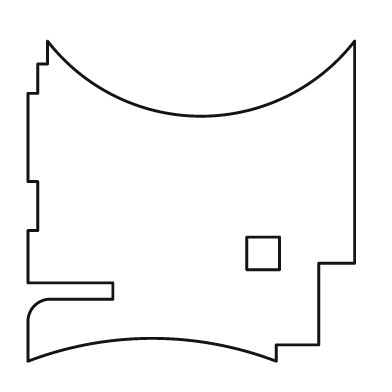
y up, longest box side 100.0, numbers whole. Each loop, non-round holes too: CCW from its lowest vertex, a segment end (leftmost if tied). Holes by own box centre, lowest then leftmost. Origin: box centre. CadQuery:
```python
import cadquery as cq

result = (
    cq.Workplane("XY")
    .moveTo(-50.0, -49.0)
    .threePointArc((-12.0, -42.0), (26.0, -49.0))
    .lineTo(26.0, -44.0)
    .lineTo(39.0, -44.0)
    .lineTo(39.0, -19.0)
    .lineTo(50.0, -19.0)
    .lineTo(50.0, 49.0)
    .threePointArc((3.0, 26.0), (-44.0, 49.0))
    .lineTo(-44.0, 42.0)
    .lineTo(-47.0, 42.0)
    .lineTo(-47.0, 33.0)
    .lineTo(-50.0, 33.0)
    .lineTo(-50.0, 6.0)
    .lineTo(-47.0, 6.0)
    .lineTo(-47.0, -9.0)
    .lineTo(-50.0, -9.0)
    .lineTo(-50.0, -25.0)
    .lineTo(-24.0, -25.0)
    .lineTo(-24.0, -30.0)
    .lineTo(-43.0, -30.0)
    .threePointArc((-48.0, -32.0), (-50.0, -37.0))
    .close()
    .moveTo(17.0, -21.0)
    .lineTo(27.0, -21.0)
    .lineTo(27.0, -11.0)
    .lineTo(17.0, -11.0)
    .close()
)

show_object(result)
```